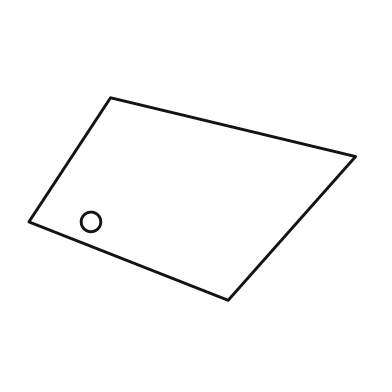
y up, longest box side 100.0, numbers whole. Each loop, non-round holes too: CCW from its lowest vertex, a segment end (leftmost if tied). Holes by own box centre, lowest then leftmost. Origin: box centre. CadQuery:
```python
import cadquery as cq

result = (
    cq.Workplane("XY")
    .moveTo(11.0, -31.0)
    .lineTo(50.0, 13.0)
    .lineTo(-25.0, 31.0)
    .lineTo(-50.0, -7.0)
    .close()
    .moveTo(-31.0, -7.0)
    .circle(3.0)
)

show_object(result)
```